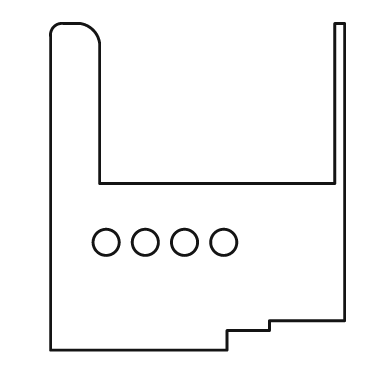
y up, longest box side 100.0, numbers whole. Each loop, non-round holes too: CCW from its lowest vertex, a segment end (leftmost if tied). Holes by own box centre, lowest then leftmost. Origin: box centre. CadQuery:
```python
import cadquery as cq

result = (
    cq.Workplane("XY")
    .moveTo(-45.0, -50.0)
    .lineTo(9.0, -50.0)
    .lineTo(9.0, -44.0)
    .lineTo(22.0, -44.0)
    .lineTo(22.0, -41.0)
    .lineTo(45.0, -41.0)
    .lineTo(45.0, 50.0)
    .lineTo(42.0, 50.0)
    .lineTo(42.0, 1.0)
    .lineTo(-30.0, 1.0)
    .lineTo(-30.0, 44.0)
    .threePointArc((-32.0, 48.0), (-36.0, 50.0))
    .lineTo(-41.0, 50.0)
    .threePointArc((-44.0, 49.0), (-45.0, 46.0))
    .close()
    .moveTo(-28.0, -17.0)
    .circle(4.0)
    .moveTo(-16.0, -17.0)
    .circle(4.0)
    .moveTo(-4.0, -17.0)
    .circle(4.0)
    .moveTo(8.0, -17.0)
    .circle(4.0)
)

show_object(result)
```